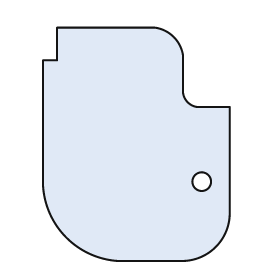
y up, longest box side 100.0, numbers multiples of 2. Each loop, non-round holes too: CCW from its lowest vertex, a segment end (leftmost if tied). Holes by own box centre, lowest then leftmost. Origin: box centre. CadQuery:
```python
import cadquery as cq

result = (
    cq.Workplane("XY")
    .moveTo(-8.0, -50.0)
    .lineTo(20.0, -50.0)
    .threePointArc((34.0, -44.0), (40.0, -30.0))
    .lineTo(40.0, 16.0)
    .lineTo(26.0, 16.0)
    .threePointArc((22.0, 18.0), (20.0, 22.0))
    .lineTo(20.0, 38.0)
    .threePointArc((16.0, 46.0), (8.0, 50.0))
    .lineTo(-34.0, 50.0)
    .lineTo(-34.0, 36.0)
    .lineTo(-40.0, 36.0)
    .lineTo(-40.0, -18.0)
    .threePointArc((-30.0, -40.0), (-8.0, -50.0))
    .close()
    .moveTo(28.0, -16.0)
    .circle(4.0)
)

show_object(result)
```